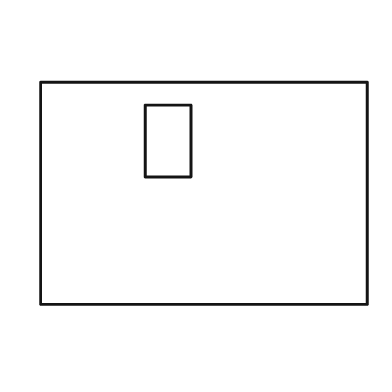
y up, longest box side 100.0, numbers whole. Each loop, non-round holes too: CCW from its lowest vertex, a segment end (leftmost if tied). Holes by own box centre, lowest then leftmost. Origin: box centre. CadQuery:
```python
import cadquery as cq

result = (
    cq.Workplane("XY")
    .moveTo(-50.0, -34.0)
    .lineTo(50.0, -34.0)
    .lineTo(50.0, 34.0)
    .lineTo(-50.0, 34.0)
    .close()
    .moveTo(-18.0, 5.0)
    .lineTo(-4.0, 5.0)
    .lineTo(-4.0, 27.0)
    .lineTo(-18.0, 27.0)
    .close()
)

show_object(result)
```